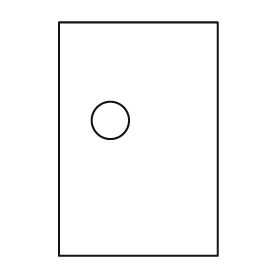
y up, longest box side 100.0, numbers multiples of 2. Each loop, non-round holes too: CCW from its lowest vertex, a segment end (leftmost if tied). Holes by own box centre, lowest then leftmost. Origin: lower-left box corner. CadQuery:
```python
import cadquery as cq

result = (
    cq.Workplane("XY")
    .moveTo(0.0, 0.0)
    .lineTo(68.0, 0.0)
    .lineTo(68.0, 100.0)
    .lineTo(0.0, 100.0)
    .close()
    .moveTo(22.0, 58.0)
    .circle(8.0)
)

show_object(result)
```